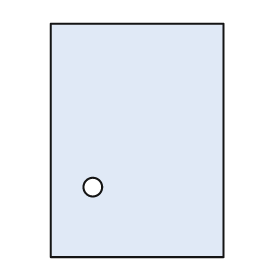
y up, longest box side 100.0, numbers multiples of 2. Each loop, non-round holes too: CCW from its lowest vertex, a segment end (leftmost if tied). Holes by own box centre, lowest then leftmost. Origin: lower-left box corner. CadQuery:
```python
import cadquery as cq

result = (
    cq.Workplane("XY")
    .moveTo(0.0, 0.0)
    .lineTo(74.0, 0.0)
    .lineTo(74.0, 100.0)
    .lineTo(0.0, 100.0)
    .close()
    .moveTo(18.0, 30.0)
    .circle(4.0)
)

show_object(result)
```